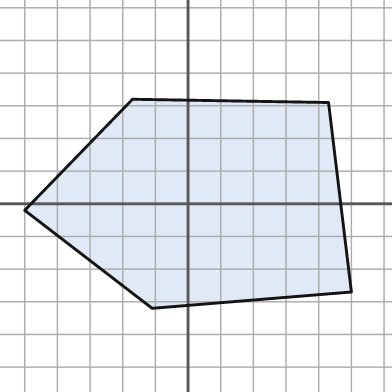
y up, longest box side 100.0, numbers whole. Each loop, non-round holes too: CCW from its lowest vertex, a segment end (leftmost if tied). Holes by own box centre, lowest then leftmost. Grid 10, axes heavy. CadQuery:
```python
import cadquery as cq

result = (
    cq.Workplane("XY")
    .moveTo(-11.0, -32.0)
    .lineTo(50.0, -27.0)
    .lineTo(43.0, 31.0)
    .lineTo(-17.0, 32.0)
    .lineTo(-50.0, -2.0)
    .close()
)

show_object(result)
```